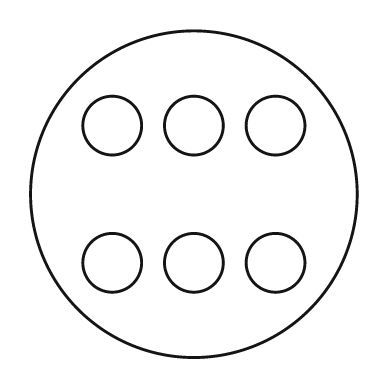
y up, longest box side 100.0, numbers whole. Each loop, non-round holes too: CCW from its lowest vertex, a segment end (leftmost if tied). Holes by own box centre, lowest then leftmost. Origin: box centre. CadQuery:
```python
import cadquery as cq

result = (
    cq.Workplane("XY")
    .moveTo(0.0, 0.0)
    .circle(50.0)
    .moveTo(-25.0, -21.0)
    .circle(9.0)
    .moveTo(0.0, -21.0)
    .circle(9.0)
    .moveTo(25.0, -21.0)
    .circle(9.0)
    .moveTo(-25.0, 21.0)
    .circle(9.0)
    .moveTo(0.0, 21.0)
    .circle(9.0)
    .moveTo(25.0, 21.0)
    .circle(9.0)
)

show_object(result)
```